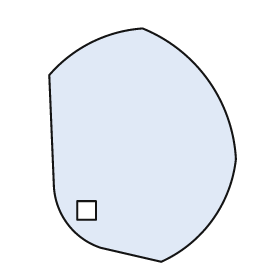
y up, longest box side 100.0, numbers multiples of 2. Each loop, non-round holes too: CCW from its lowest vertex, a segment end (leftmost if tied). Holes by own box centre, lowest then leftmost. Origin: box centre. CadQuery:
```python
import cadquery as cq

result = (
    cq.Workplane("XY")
    .moveTo(8.0, -50.0)
    .threePointArc((30.0, -32.0), (40.0, -6.0))
    .threePointArc((28.0, 28.0), (0.0, 50.0))
    .threePointArc((-22.0, 44.0), (-40.0, 30.0))
    .lineTo(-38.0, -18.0)
    .threePointArc((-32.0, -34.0), (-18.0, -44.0))
    .close()
    .moveTo(-28.0, -32.0)
    .lineTo(-20.0, -32.0)
    .lineTo(-20.0, -24.0)
    .lineTo(-28.0, -24.0)
    .close()
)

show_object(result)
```